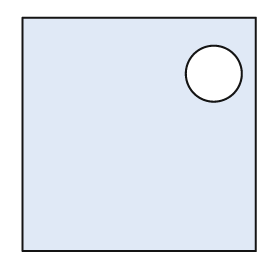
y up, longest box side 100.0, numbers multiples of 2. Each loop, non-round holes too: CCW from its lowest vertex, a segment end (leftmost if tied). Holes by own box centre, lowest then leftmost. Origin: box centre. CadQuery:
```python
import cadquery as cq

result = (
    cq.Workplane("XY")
    .moveTo(-50.0, -50.0)
    .lineTo(50.0, -50.0)
    .lineTo(50.0, 50.0)
    .lineTo(-50.0, 50.0)
    .close()
    .moveTo(32.0, 26.0)
    .circle(12.0)
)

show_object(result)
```